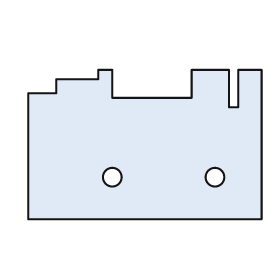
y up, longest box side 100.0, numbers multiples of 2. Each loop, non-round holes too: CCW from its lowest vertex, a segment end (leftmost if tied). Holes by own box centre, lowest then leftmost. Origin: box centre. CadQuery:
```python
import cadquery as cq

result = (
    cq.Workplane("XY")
    .moveTo(-50.0, -32.0)
    .lineTo(50.0, -32.0)
    .lineTo(50.0, 32.0)
    .lineTo(40.0, 32.0)
    .lineTo(40.0, 16.0)
    .lineTo(36.0, 16.0)
    .lineTo(36.0, 32.0)
    .lineTo(20.0, 32.0)
    .lineTo(20.0, 20.0)
    .lineTo(-14.0, 20.0)
    .lineTo(-14.0, 32.0)
    .lineTo(-20.0, 32.0)
    .lineTo(-20.0, 28.0)
    .lineTo(-38.0, 28.0)
    .lineTo(-38.0, 22.0)
    .lineTo(-50.0, 22.0)
    .close()
    .moveTo(-14.0, -14.0)
    .circle(4.0)
    .moveTo(30.0, -14.0)
    .circle(4.0)
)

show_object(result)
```